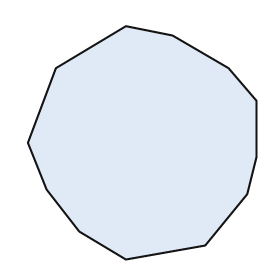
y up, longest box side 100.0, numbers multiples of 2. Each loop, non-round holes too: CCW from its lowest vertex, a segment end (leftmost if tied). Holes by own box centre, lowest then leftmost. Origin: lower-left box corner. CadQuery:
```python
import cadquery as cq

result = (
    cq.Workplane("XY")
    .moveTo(42.0, 0.0)
    .lineTo(76.0, 6.0)
    .lineTo(94.0, 28.0)
    .lineTo(98.0, 44.0)
    .lineTo(98.0, 68.0)
    .lineTo(86.0, 82.0)
    .lineTo(62.0, 96.0)
    .lineTo(42.0, 100.0)
    .lineTo(12.0, 82.0)
    .lineTo(0.0, 50.0)
    .lineTo(8.0, 30.0)
    .lineTo(22.0, 12.0)
    .close()
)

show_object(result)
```